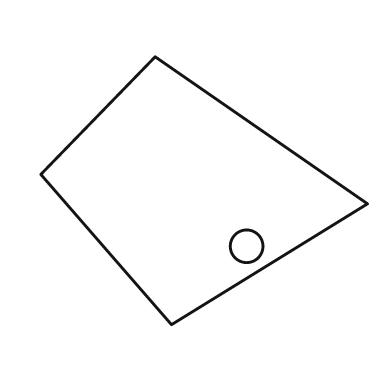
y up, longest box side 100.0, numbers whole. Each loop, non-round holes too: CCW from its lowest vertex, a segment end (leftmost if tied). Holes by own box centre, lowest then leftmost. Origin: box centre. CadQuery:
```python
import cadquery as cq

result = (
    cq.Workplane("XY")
    .moveTo(-10.0, -41.0)
    .lineTo(50.0, -4.0)
    .lineTo(-15.0, 41.0)
    .lineTo(-50.0, 5.0)
    .close()
    .moveTo(13.0, -17.0)
    .circle(5.0)
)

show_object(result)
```